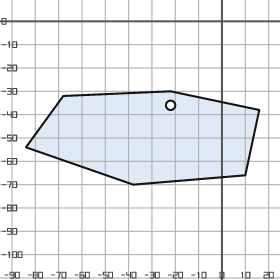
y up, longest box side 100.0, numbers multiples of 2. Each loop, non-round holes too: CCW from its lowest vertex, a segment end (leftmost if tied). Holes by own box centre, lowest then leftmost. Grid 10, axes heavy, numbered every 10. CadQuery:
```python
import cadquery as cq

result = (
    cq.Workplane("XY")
    .moveTo(-38.0, -70.0)
    .lineTo(10.0, -66.0)
    .lineTo(16.0, -38.0)
    .lineTo(-22.0, -30.0)
    .lineTo(-68.0, -32.0)
    .lineTo(-84.0, -54.0)
    .close()
    .moveTo(-22.0, -36.0)
    .circle(2.0)
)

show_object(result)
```